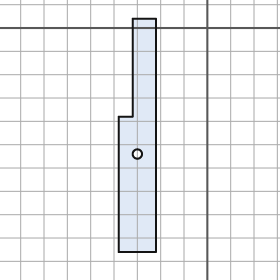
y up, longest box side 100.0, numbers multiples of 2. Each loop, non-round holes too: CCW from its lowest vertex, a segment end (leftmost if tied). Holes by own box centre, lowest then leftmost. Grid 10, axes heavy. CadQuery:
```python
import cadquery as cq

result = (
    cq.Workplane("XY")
    .moveTo(-38.0, -96.0)
    .lineTo(-22.0, -96.0)
    .lineTo(-22.0, 4.0)
    .lineTo(-32.0, 4.0)
    .lineTo(-32.0, -38.0)
    .lineTo(-38.0, -38.0)
    .close()
    .moveTo(-30.0, -54.0)
    .circle(2.0)
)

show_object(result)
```